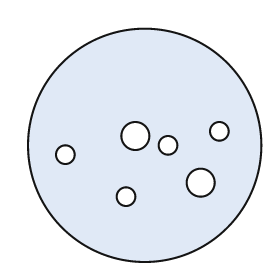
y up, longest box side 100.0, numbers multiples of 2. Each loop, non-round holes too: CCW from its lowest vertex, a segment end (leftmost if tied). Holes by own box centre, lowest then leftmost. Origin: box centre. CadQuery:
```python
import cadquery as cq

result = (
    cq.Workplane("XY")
    .moveTo(0.0, 0.0)
    .circle(50.0)
    .moveTo(-8.0, -22.0)
    .circle(4.0)
    .moveTo(24.0, -16.0)
    .circle(6.0)
    .moveTo(-34.0, -4.0)
    .circle(4.0)
    .moveTo(10.0, 0.0)
    .circle(4.0)
    .moveTo(-4.0, 4.0)
    .circle(6.0)
    .moveTo(32.0, 6.0)
    .circle(4.0)
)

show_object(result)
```